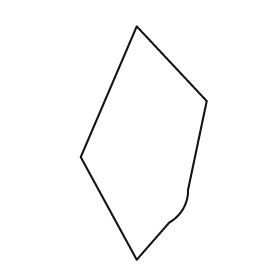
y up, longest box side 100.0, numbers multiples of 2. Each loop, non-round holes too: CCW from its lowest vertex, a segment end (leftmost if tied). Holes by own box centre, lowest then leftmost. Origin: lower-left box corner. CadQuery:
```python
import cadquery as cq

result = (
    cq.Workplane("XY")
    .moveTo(24.0, 0.0)
    .lineTo(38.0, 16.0)
    .threePointArc((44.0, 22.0), (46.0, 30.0))
    .lineTo(54.0, 68.0)
    .lineTo(24.0, 100.0)
    .lineTo(0.0, 44.0)
    .close()
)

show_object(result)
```